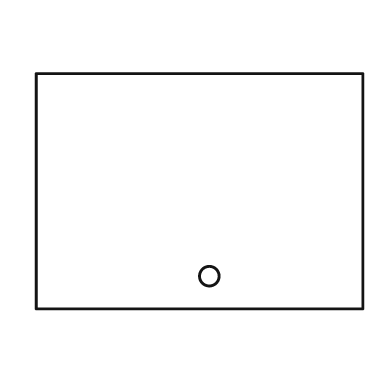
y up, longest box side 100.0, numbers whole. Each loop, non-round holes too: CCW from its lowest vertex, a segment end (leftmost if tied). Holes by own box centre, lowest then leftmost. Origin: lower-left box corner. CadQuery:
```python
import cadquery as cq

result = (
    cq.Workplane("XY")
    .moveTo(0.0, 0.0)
    .lineTo(100.0, 0.0)
    .lineTo(100.0, 72.0)
    .lineTo(0.0, 72.0)
    .close()
    .moveTo(53.0, 10.0)
    .circle(3.0)
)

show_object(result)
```